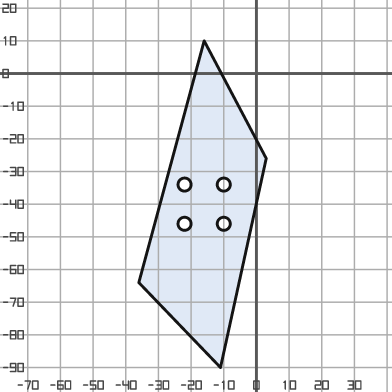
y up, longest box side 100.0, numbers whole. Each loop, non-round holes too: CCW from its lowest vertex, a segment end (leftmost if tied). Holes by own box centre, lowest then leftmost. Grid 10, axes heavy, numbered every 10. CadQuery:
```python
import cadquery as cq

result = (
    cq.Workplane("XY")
    .moveTo(-11.0, -90.0)
    .lineTo(3.0, -26.0)
    .lineTo(-16.0, 10.0)
    .lineTo(-36.0, -64.0)
    .close()
    .moveTo(-22.0, -46.0)
    .circle(2.0)
    .moveTo(-10.0, -46.0)
    .circle(2.0)
    .moveTo(-22.0, -34.0)
    .circle(2.0)
    .moveTo(-10.0, -34.0)
    .circle(2.0)
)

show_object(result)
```